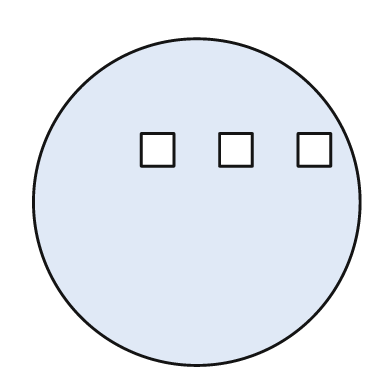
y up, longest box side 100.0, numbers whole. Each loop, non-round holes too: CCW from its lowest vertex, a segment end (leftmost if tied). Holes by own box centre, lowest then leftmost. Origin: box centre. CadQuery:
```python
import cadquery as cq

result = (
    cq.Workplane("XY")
    .moveTo(0.0, 0.0)
    .circle(50.0)
    .moveTo(-17.0, 11.0)
    .lineTo(-7.0, 11.0)
    .lineTo(-7.0, 21.0)
    .lineTo(-17.0, 21.0)
    .close()
    .moveTo(7.0, 11.0)
    .lineTo(17.0, 11.0)
    .lineTo(17.0, 21.0)
    .lineTo(7.0, 21.0)
    .close()
    .moveTo(31.0, 11.0)
    .lineTo(41.0, 11.0)
    .lineTo(41.0, 21.0)
    .lineTo(31.0, 21.0)
    .close()
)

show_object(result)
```